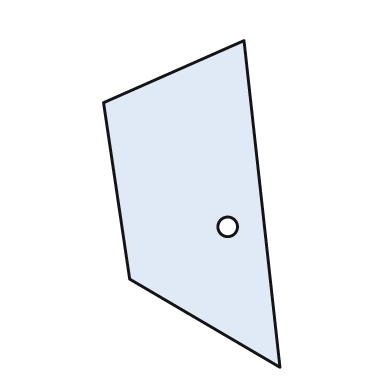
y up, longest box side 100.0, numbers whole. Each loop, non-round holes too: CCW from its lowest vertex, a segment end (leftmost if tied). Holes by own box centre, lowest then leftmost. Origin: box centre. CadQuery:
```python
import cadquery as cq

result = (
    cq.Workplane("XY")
    .moveTo(27.0, -50.0)
    .lineTo(16.0, 50.0)
    .lineTo(-27.0, 31.0)
    .lineTo(-19.0, -23.0)
    .close()
    .moveTo(11.0, -7.0)
    .circle(3.0)
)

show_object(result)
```